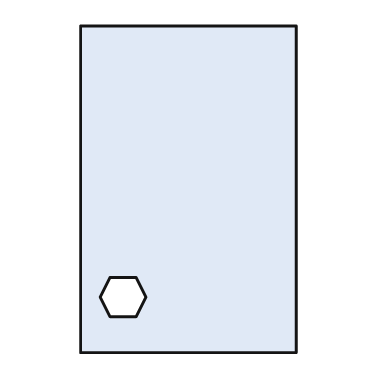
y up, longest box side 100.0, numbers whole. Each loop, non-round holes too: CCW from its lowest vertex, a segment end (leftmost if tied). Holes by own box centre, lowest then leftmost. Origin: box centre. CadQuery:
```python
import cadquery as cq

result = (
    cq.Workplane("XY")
    .moveTo(-33.0, -50.0)
    .lineTo(33.0, -50.0)
    .lineTo(33.0, 50.0)
    .lineTo(-33.0, 50.0)
    .close()
    .moveTo(-24.0, -39.0)
    .lineTo(-16.0, -39.0)
    .lineTo(-13.0, -33.0)
    .lineTo(-16.0, -27.0)
    .lineTo(-24.0, -27.0)
    .lineTo(-27.0, -33.0)
    .close()
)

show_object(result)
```